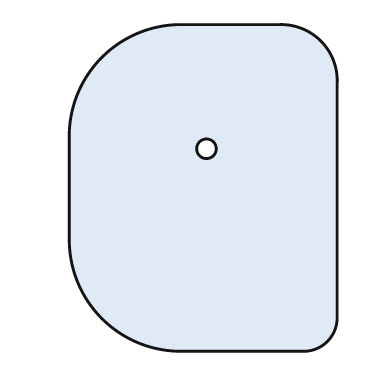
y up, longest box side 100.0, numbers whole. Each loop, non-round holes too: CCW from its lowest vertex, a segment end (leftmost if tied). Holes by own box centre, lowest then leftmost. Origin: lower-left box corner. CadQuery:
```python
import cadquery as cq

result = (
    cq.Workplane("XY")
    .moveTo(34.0, 0.0)
    .lineTo(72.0, 0.0)
    .threePointArc((79.0, 3.0), (82.0, 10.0))
    .lineTo(82.0, 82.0)
    .threePointArc((77.0, 95.0), (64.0, 100.0))
    .lineTo(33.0, 100.0)
    .threePointArc((10.0, 90.0), (0.0, 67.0))
    .lineTo(0.0, 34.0)
    .threePointArc((10.0, 10.0), (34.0, 0.0))
    .close()
    .moveTo(42.0, 62.0)
    .circle(3.0)
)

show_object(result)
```